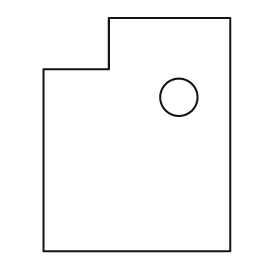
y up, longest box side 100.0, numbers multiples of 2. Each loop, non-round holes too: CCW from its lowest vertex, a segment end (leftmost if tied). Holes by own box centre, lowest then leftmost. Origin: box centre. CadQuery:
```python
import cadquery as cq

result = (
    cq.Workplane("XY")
    .moveTo(-40.0, -50.0)
    .lineTo(40.0, -50.0)
    .lineTo(40.0, 50.0)
    .lineTo(-12.0, 50.0)
    .lineTo(-12.0, 28.0)
    .lineTo(-40.0, 28.0)
    .close()
    .moveTo(18.0, 16.0)
    .circle(8.0)
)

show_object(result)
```